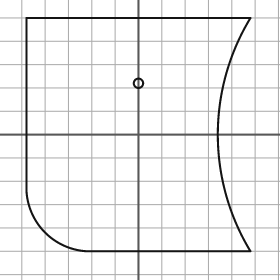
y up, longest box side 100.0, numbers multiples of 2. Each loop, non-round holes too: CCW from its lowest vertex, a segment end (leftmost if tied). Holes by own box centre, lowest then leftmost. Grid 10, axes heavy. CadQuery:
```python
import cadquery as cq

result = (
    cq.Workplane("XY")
    .moveTo(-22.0, -50.0)
    .lineTo(48.0, -50.0)
    .threePointArc((34.0, 0.0), (48.0, 50.0))
    .lineTo(-48.0, 50.0)
    .lineTo(-48.0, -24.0)
    .threePointArc((-40.0, -42.0), (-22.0, -50.0))
    .close()
    .moveTo(0.0, 22.0)
    .circle(2.0)
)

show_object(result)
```